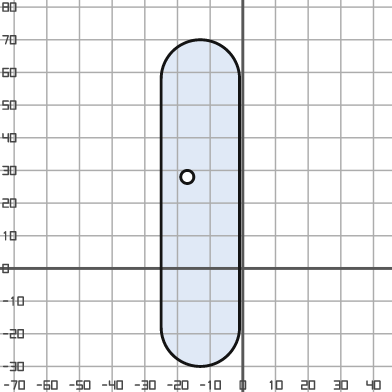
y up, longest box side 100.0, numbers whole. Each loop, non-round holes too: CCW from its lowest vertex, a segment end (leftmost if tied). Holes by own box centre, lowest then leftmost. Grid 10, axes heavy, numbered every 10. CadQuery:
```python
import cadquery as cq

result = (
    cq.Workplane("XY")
    .moveTo(-25.0, -18.0)
    .threePointArc((-13.0, -30.0), (-1.0, -18.0))
    .lineTo(-1.0, 58.0)
    .threePointArc((-13.0, 70.0), (-25.0, 58.0))
    .close()
    .moveTo(-17.0, 28.0)
    .circle(2.0)
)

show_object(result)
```